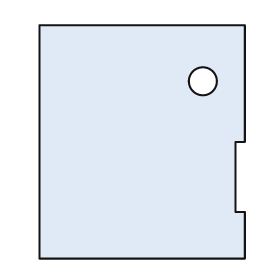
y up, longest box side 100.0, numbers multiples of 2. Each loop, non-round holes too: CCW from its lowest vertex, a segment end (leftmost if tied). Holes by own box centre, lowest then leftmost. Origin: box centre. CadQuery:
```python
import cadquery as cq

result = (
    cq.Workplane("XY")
    .moveTo(-44.0, -50.0)
    .lineTo(44.0, -50.0)
    .lineTo(44.0, -30.0)
    .lineTo(40.0, -30.0)
    .lineTo(40.0, 0.0)
    .lineTo(44.0, 0.0)
    .lineTo(44.0, 50.0)
    .lineTo(-44.0, 50.0)
    .close()
    .moveTo(26.0, 26.0)
    .circle(6.0)
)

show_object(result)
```